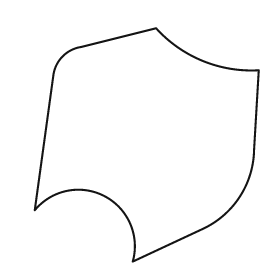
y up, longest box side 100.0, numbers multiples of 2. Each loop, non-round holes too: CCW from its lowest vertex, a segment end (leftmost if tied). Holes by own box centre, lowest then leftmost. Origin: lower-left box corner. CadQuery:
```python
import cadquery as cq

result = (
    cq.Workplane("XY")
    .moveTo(42.0, 0.0)
    .lineTo(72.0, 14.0)
    .threePointArc((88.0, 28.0), (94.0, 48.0))
    .lineTo(96.0, 82.0)
    .threePointArc((72.0, 86.0), (52.0, 100.0))
    .lineTo(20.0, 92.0)
    .threePointArc((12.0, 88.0), (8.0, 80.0))
    .lineTo(0.0, 22.0)
    .threePointArc((30.0, 28.0), (42.0, 0.0))
    .close()
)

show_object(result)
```